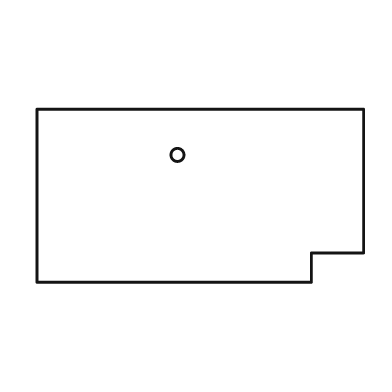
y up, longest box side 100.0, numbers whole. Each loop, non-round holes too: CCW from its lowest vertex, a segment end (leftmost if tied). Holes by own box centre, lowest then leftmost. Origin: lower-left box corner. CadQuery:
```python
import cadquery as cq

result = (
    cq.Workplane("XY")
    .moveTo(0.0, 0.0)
    .lineTo(84.0, 0.0)
    .lineTo(84.0, 9.0)
    .lineTo(100.0, 9.0)
    .lineTo(100.0, 53.0)
    .lineTo(0.0, 53.0)
    .close()
    .moveTo(43.0, 39.0)
    .circle(2.0)
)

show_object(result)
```